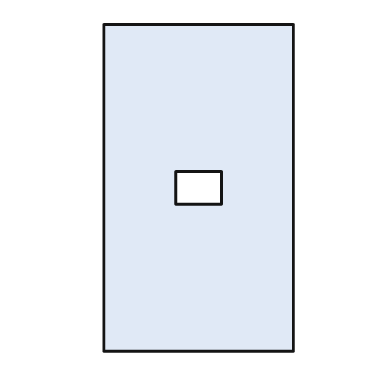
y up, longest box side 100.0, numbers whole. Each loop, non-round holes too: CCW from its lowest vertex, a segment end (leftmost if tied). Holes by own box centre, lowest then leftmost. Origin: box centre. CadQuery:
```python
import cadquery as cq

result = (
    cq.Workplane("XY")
    .moveTo(-29.0, -50.0)
    .lineTo(29.0, -50.0)
    .lineTo(29.0, 50.0)
    .lineTo(-29.0, 50.0)
    .close()
    .moveTo(-7.0, -5.0)
    .lineTo(7.0, -5.0)
    .lineTo(7.0, 5.0)
    .lineTo(-7.0, 5.0)
    .close()
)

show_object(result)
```